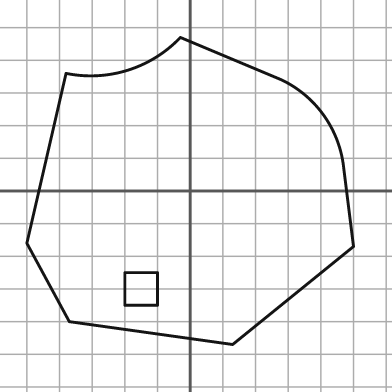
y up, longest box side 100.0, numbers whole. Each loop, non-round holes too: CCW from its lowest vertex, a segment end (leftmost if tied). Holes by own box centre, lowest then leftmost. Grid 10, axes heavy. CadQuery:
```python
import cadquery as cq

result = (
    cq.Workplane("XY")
    .moveTo(13.0, -47.0)
    .lineTo(50.0, -17.0)
    .lineTo(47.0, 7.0)
    .threePointArc((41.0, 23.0), (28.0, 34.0))
    .lineTo(-3.0, 47.0)
    .threePointArc((-19.0, 37.0), (-38.0, 36.0))
    .lineTo(-50.0, -16.0)
    .lineTo(-37.0, -40.0)
    .close()
    .moveTo(-20.0, -35.0)
    .lineTo(-10.0, -35.0)
    .lineTo(-10.0, -25.0)
    .lineTo(-20.0, -25.0)
    .close()
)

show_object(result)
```